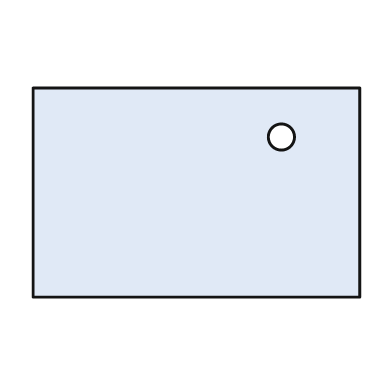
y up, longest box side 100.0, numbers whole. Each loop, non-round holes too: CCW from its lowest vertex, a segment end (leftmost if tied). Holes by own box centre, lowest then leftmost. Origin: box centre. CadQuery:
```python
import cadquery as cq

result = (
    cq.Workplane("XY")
    .moveTo(-50.0, -32.0)
    .lineTo(50.0, -32.0)
    .lineTo(50.0, 32.0)
    .lineTo(-50.0, 32.0)
    .close()
    .moveTo(26.0, 17.0)
    .circle(4.0)
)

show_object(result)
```